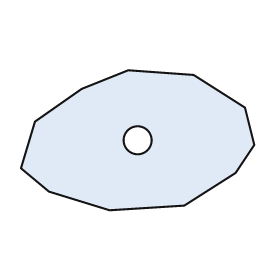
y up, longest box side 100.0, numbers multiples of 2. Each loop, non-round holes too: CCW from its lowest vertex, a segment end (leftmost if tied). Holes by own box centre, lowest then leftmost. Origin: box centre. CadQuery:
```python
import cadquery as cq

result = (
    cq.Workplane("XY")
    .moveTo(-12.0, -30.0)
    .lineTo(20.0, -28.0)
    .lineTo(42.0, -14.0)
    .lineTo(50.0, -2.0)
    .lineTo(46.0, 14.0)
    .lineTo(24.0, 28.0)
    .lineTo(-4.0, 30.0)
    .lineTo(-24.0, 22.0)
    .lineTo(-44.0, 8.0)
    .lineTo(-50.0, -12.0)
    .lineTo(-38.0, -22.0)
    .close()
    .moveTo(0.0, 0.0)
    .circle(6.0)
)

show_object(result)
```